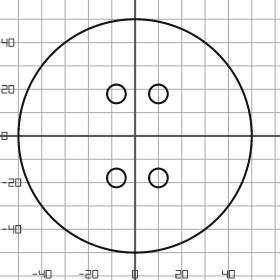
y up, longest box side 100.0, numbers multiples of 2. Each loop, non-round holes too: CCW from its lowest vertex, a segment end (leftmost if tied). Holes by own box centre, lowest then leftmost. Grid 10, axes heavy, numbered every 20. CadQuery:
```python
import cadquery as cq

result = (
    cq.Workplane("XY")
    .moveTo(0.0, 0.0)
    .circle(50.0)
    .moveTo(-8.0, -18.0)
    .circle(4.0)
    .moveTo(10.0, -18.0)
    .circle(4.0)
    .moveTo(-8.0, 18.0)
    .circle(4.0)
    .moveTo(10.0, 18.0)
    .circle(4.0)
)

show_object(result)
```